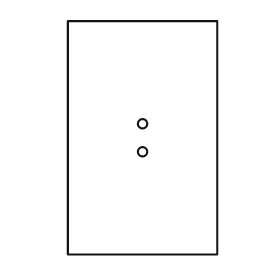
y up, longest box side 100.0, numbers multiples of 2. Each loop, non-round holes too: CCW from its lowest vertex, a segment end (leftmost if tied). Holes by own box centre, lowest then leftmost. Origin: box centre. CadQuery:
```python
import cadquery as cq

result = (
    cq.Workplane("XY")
    .moveTo(-32.0, -50.0)
    .lineTo(32.0, -50.0)
    .lineTo(32.0, 50.0)
    .lineTo(-32.0, 50.0)
    .close()
    .moveTo(0.0, -6.0)
    .circle(2.0)
    .moveTo(0.0, 6.0)
    .circle(2.0)
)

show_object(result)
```